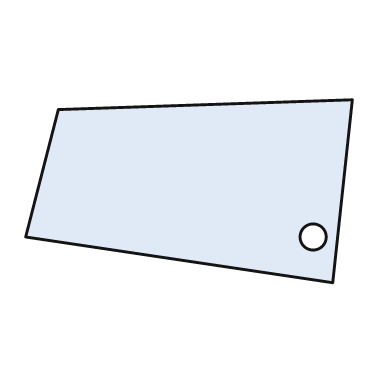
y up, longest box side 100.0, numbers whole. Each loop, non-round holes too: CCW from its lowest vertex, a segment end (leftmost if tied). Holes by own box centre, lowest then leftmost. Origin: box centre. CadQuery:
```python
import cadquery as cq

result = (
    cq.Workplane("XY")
    .moveTo(44.0, -28.0)
    .lineTo(50.0, 28.0)
    .lineTo(-40.0, 25.0)
    .lineTo(-50.0, -14.0)
    .close()
    .moveTo(38.0, -14.0)
    .circle(4.0)
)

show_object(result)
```